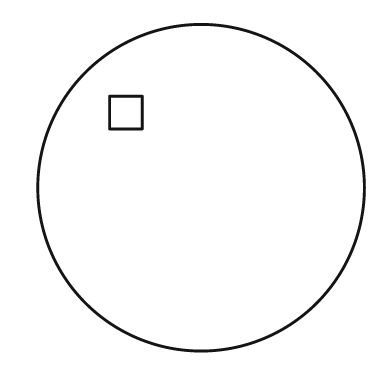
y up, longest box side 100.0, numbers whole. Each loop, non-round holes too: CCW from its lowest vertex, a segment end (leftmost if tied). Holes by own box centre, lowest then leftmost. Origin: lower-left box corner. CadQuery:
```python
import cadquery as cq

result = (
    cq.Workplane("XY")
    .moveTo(50.0, 50.0)
    .circle(50.0)
    .moveTo(22.0, 68.0)
    .lineTo(32.0, 68.0)
    .lineTo(32.0, 78.0)
    .lineTo(22.0, 78.0)
    .close()
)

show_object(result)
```